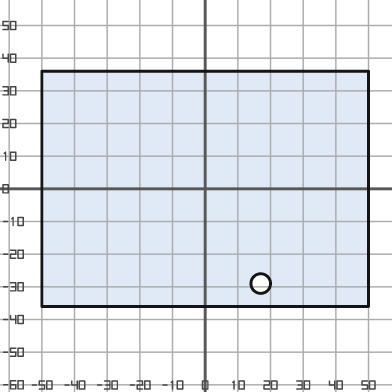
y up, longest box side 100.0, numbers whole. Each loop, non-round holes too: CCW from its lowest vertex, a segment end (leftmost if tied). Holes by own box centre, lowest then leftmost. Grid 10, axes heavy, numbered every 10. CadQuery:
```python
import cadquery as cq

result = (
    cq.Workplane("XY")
    .moveTo(-50.0, -36.0)
    .lineTo(50.0, -36.0)
    .lineTo(50.0, 36.0)
    .lineTo(-50.0, 36.0)
    .close()
    .moveTo(17.0, -29.0)
    .circle(3.0)
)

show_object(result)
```